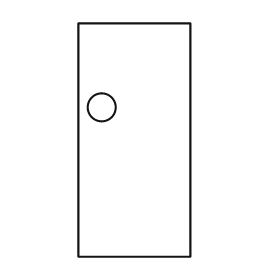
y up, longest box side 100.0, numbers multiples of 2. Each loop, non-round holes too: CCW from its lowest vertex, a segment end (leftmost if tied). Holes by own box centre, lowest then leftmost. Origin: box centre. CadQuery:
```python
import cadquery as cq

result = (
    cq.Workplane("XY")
    .moveTo(-24.0, -50.0)
    .lineTo(24.0, -50.0)
    .lineTo(24.0, 50.0)
    .lineTo(-24.0, 50.0)
    .close()
    .moveTo(-14.0, 14.0)
    .circle(6.0)
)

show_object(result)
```